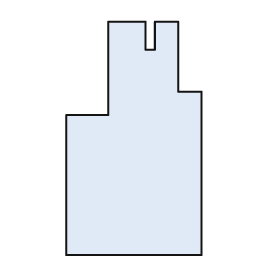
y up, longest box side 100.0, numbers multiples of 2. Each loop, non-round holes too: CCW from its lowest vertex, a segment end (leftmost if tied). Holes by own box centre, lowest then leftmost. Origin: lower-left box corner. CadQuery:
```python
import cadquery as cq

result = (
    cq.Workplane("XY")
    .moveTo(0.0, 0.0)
    .lineTo(58.0, 0.0)
    .lineTo(58.0, 70.0)
    .lineTo(48.0, 70.0)
    .lineTo(48.0, 100.0)
    .lineTo(38.0, 100.0)
    .lineTo(38.0, 88.0)
    .lineTo(34.0, 88.0)
    .lineTo(34.0, 100.0)
    .lineTo(18.0, 100.0)
    .lineTo(18.0, 60.0)
    .lineTo(0.0, 60.0)
    .close()
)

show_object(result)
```